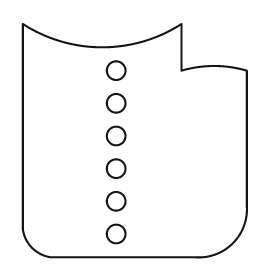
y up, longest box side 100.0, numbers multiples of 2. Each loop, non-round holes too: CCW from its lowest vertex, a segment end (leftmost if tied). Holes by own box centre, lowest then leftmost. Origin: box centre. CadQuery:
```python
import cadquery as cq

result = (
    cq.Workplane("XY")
    .moveTo(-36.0, -50.0)
    .lineTo(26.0, -50.0)
    .threePointArc((42.0, -44.0), (48.0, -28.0))
    .lineTo(48.0, 30.0)
    .threePointArc((34.0, 32.0), (20.0, 30.0))
    .lineTo(20.0, 50.0)
    .threePointArc((-14.0, 40.0), (-48.0, 50.0))
    .lineTo(-48.0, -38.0)
    .threePointArc((-44.0, -46.0), (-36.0, -50.0))
    .close()
    .moveTo(-8.0, -40.0)
    .circle(4.0)
    .moveTo(-8.0, -26.0)
    .circle(4.0)
    .moveTo(-8.0, -12.0)
    .circle(4.0)
    .moveTo(-8.0, 2.0)
    .circle(4.0)
    .moveTo(-8.0, 16.0)
    .circle(4.0)
    .moveTo(-8.0, 30.0)
    .circle(4.0)
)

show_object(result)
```